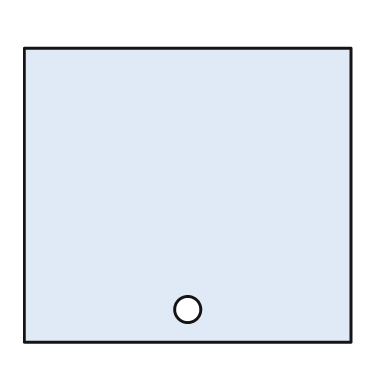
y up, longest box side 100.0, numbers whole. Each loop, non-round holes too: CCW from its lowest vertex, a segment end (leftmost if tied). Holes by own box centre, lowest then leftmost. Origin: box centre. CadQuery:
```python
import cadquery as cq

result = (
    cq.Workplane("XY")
    .moveTo(-50.0, -45.0)
    .lineTo(50.0, -45.0)
    .lineTo(50.0, 45.0)
    .lineTo(-50.0, 45.0)
    .close()
    .moveTo(0.0, -35.0)
    .circle(4.0)
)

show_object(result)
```